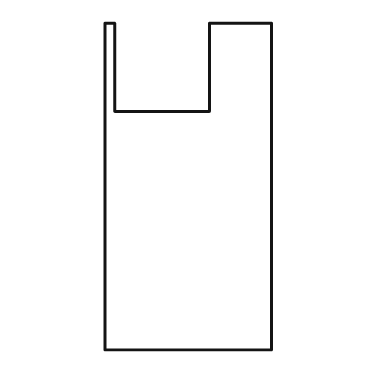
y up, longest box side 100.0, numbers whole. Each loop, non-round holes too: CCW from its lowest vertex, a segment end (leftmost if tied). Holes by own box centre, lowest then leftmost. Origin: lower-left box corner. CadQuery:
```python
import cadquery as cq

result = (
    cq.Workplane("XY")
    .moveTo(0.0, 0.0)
    .lineTo(51.0, 0.0)
    .lineTo(51.0, 100.0)
    .lineTo(32.0, 100.0)
    .lineTo(32.0, 73.0)
    .lineTo(3.0, 73.0)
    .lineTo(3.0, 100.0)
    .lineTo(0.0, 100.0)
    .close()
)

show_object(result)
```